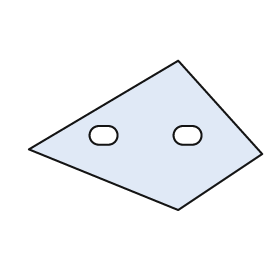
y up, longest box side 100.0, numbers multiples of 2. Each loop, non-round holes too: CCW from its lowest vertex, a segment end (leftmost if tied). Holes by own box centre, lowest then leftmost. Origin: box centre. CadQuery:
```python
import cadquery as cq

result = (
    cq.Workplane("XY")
    .moveTo(14.0, -32.0)
    .lineTo(50.0, -8.0)
    .lineTo(14.0, 32.0)
    .lineTo(-50.0, -6.0)
    .close()
    .moveTo(-20.0, -4.0)
    .lineTo(-16.0, -4.0)
    .threePointArc((-12.0, 0.0), (-16.0, 4.0))
    .lineTo(-20.0, 4.0)
    .threePointArc((-24.0, 0.0), (-20.0, -4.0))
    .close()
    .moveTo(16.0, -4.0)
    .lineTo(20.0, -4.0)
    .threePointArc((24.0, 0.0), (20.0, 4.0))
    .lineTo(16.0, 4.0)
    .threePointArc((12.0, 0.0), (16.0, -4.0))
    .close()
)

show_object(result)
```